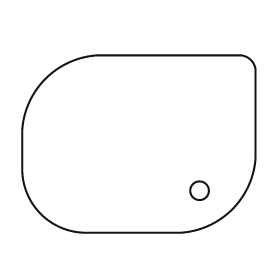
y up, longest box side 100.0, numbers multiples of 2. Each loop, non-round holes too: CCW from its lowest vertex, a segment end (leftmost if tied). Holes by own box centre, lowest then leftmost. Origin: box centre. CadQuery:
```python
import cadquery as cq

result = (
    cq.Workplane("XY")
    .moveTo(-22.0, -38.0)
    .lineTo(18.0, -38.0)
    .threePointArc((40.0, -28.0), (50.0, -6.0))
    .lineTo(50.0, 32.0)
    .threePointArc((48.0, 36.0), (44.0, 38.0))
    .lineTo(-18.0, 38.0)
    .threePointArc((-40.0, 28.0), (-50.0, 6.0))
    .lineTo(-50.0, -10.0)
    .threePointArc((-42.0, -30.0), (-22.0, -38.0))
    .close()
    .moveTo(26.0, -20.0)
    .circle(4.0)
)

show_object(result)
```